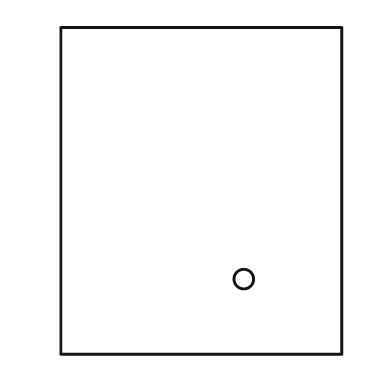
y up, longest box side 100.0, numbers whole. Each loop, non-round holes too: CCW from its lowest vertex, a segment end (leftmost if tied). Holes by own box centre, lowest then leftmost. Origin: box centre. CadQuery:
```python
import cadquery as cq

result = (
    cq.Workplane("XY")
    .moveTo(-43.0, -50.0)
    .lineTo(43.0, -50.0)
    .lineTo(43.0, 50.0)
    .lineTo(-43.0, 50.0)
    .close()
    .moveTo(13.0, -27.0)
    .circle(3.0)
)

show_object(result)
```